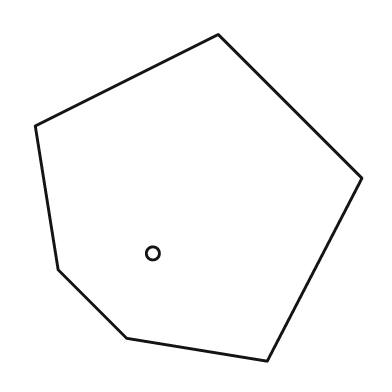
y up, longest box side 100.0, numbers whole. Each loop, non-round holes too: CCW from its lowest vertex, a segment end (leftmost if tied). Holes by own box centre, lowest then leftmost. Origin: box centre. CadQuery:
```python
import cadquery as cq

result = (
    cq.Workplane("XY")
    .moveTo(21.0, -50.0)
    .lineTo(50.0, 6.0)
    .lineTo(6.0, 50.0)
    .lineTo(-50.0, 22.0)
    .lineTo(-43.0, -22.0)
    .lineTo(-22.0, -43.0)
    .close()
    .moveTo(-14.0, -17.0)
    .circle(2.0)
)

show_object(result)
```